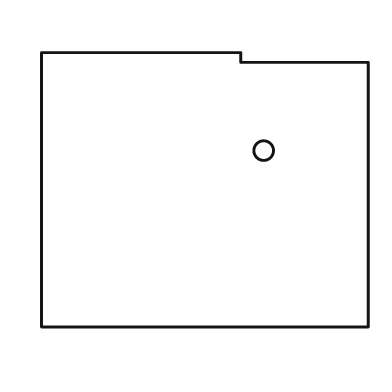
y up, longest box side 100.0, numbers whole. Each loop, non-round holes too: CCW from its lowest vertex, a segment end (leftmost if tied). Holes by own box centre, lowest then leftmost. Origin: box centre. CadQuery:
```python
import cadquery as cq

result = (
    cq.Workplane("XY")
    .moveTo(-50.0, -42.0)
    .lineTo(50.0, -42.0)
    .lineTo(50.0, 39.0)
    .lineTo(11.0, 39.0)
    .lineTo(11.0, 42.0)
    .lineTo(-50.0, 42.0)
    .close()
    .moveTo(18.0, 12.0)
    .circle(3.0)
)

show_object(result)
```